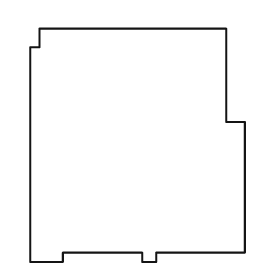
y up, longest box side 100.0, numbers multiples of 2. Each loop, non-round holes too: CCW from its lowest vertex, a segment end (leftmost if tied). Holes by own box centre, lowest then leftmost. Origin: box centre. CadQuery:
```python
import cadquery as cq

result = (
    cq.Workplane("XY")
    .moveTo(-46.0, -50.0)
    .lineTo(-32.0, -50.0)
    .lineTo(-32.0, -46.0)
    .lineTo(2.0, -46.0)
    .lineTo(2.0, -50.0)
    .lineTo(8.0, -50.0)
    .lineTo(8.0, -46.0)
    .lineTo(46.0, -46.0)
    .lineTo(46.0, 10.0)
    .lineTo(38.0, 10.0)
    .lineTo(38.0, 50.0)
    .lineTo(-42.0, 50.0)
    .lineTo(-42.0, 42.0)
    .lineTo(-46.0, 42.0)
    .close()
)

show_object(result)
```